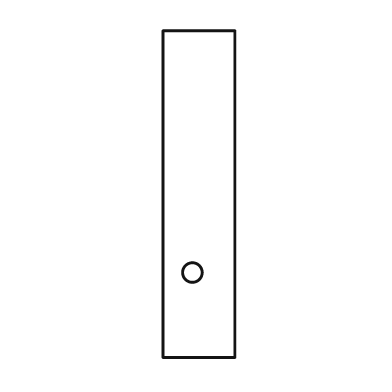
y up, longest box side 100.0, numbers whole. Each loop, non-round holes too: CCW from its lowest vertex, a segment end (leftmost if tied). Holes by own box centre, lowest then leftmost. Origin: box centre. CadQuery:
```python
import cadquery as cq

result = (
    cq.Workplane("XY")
    .moveTo(-11.0, -50.0)
    .lineTo(11.0, -50.0)
    .lineTo(11.0, 50.0)
    .lineTo(-11.0, 50.0)
    .close()
    .moveTo(-2.0, -24.0)
    .circle(3.0)
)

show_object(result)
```